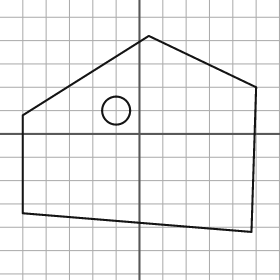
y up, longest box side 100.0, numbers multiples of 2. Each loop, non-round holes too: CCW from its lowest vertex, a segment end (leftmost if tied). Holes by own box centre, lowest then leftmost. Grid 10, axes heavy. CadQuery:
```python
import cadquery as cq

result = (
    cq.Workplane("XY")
    .moveTo(48.0, -42.0)
    .lineTo(50.0, 20.0)
    .lineTo(4.0, 42.0)
    .lineTo(-50.0, 8.0)
    .lineTo(-50.0, -34.0)
    .close()
    .moveTo(-10.0, 10.0)
    .circle(6.0)
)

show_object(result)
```